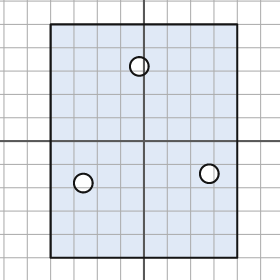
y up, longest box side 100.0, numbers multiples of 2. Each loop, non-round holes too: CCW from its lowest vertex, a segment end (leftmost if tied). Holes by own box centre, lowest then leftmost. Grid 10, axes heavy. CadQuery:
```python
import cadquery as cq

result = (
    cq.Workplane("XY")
    .moveTo(-40.0, -50.0)
    .lineTo(40.0, -50.0)
    .lineTo(40.0, 50.0)
    .lineTo(-40.0, 50.0)
    .close()
    .moveTo(-26.0, -18.0)
    .circle(4.0)
    .moveTo(28.0, -14.0)
    .circle(4.0)
    .moveTo(-2.0, 32.0)
    .circle(4.0)
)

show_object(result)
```